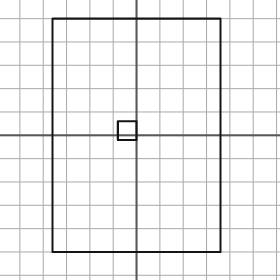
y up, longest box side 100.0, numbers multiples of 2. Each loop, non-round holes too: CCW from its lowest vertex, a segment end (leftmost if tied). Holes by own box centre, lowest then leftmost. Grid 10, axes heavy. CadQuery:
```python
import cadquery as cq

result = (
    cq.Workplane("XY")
    .moveTo(-36.0, -50.0)
    .lineTo(36.0, -50.0)
    .lineTo(36.0, 50.0)
    .lineTo(-36.0, 50.0)
    .close()
    .moveTo(-8.0, -2.0)
    .lineTo(0.0, -2.0)
    .lineTo(0.0, 6.0)
    .lineTo(-8.0, 6.0)
    .close()
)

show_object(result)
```